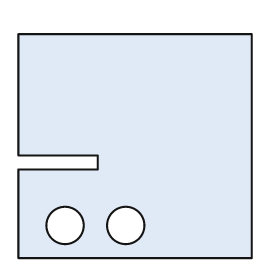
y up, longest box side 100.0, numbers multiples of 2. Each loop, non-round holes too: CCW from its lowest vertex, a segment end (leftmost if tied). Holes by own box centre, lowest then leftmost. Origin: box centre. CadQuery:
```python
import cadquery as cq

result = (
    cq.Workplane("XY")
    .moveTo(-50.0, -48.0)
    .lineTo(50.0, -48.0)
    .lineTo(50.0, 48.0)
    .lineTo(-50.0, 48.0)
    .lineTo(-50.0, -4.0)
    .lineTo(-16.0, -4.0)
    .lineTo(-16.0, -10.0)
    .lineTo(-50.0, -10.0)
    .close()
    .moveTo(-30.0, -34.0)
    .circle(8.0)
    .moveTo(-4.0, -34.0)
    .circle(8.0)
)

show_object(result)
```